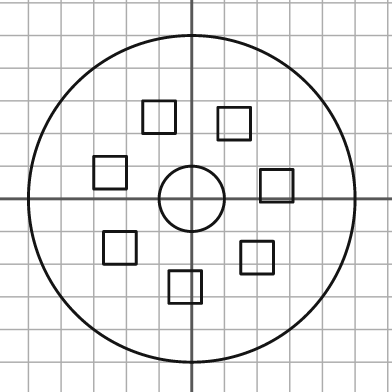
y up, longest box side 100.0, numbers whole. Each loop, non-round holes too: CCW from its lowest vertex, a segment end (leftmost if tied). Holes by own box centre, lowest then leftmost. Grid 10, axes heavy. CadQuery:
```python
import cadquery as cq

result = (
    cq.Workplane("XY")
    .moveTo(0.0, 0.0)
    .circle(50.0)
    .moveTo(-7.0, -32.0)
    .lineTo(3.0, -32.0)
    .lineTo(3.0, -22.0)
    .lineTo(-7.0, -22.0)
    .close()
    .moveTo(15.0, -23.0)
    .lineTo(25.0, -23.0)
    .lineTo(25.0, -13.0)
    .lineTo(15.0, -13.0)
    .close()
    .moveTo(-27.0, -20.0)
    .lineTo(-17.0, -20.0)
    .lineTo(-17.0, -10.0)
    .lineTo(-27.0, -10.0)
    .close()
    .moveTo(0.0, 0.0)
    .circle(10.0)
    .moveTo(21.0, -1.0)
    .lineTo(31.0, -1.0)
    .lineTo(31.0, 9.0)
    .lineTo(21.0, 9.0)
    .close()
    .moveTo(-30.0, 3.0)
    .lineTo(-20.0, 3.0)
    .lineTo(-20.0, 13.0)
    .lineTo(-30.0, 13.0)
    .close()
    .moveTo(8.0, 18.0)
    .lineTo(18.0, 18.0)
    .lineTo(18.0, 28.0)
    .lineTo(8.0, 28.0)
    .close()
    .moveTo(-15.0, 20.0)
    .lineTo(-5.0, 20.0)
    .lineTo(-5.0, 30.0)
    .lineTo(-15.0, 30.0)
    .close()
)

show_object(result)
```